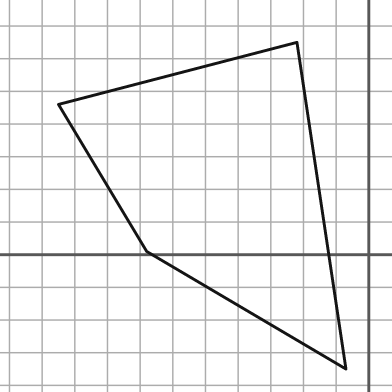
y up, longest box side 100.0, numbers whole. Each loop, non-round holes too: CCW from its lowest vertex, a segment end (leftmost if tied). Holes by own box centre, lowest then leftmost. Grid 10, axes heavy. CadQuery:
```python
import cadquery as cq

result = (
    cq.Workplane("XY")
    .moveTo(-7.0, -35.0)
    .lineTo(-22.0, 65.0)
    .lineTo(-95.0, 46.0)
    .lineTo(-68.0, 1.0)
    .close()
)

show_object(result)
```